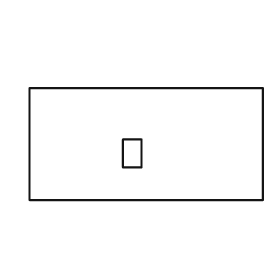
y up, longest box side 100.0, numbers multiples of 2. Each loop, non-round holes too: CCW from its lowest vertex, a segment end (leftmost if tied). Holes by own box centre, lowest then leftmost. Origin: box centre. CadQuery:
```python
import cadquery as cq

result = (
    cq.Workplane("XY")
    .moveTo(-50.0, -24.0)
    .lineTo(50.0, -24.0)
    .lineTo(50.0, 24.0)
    .lineTo(-50.0, 24.0)
    .close()
    .moveTo(-10.0, -10.0)
    .lineTo(-2.0, -10.0)
    .lineTo(-2.0, 2.0)
    .lineTo(-10.0, 2.0)
    .close()
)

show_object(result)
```